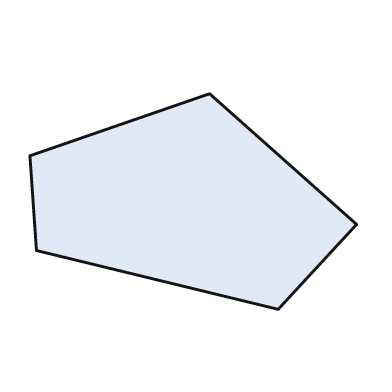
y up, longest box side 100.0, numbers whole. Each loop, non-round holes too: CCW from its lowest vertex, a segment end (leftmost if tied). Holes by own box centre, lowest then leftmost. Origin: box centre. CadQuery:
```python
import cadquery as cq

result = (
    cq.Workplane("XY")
    .moveTo(26.0, -33.0)
    .lineTo(50.0, -7.0)
    .lineTo(5.0, 33.0)
    .lineTo(-50.0, 14.0)
    .lineTo(-48.0, -15.0)
    .close()
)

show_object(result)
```